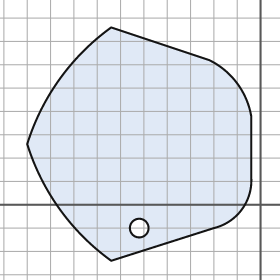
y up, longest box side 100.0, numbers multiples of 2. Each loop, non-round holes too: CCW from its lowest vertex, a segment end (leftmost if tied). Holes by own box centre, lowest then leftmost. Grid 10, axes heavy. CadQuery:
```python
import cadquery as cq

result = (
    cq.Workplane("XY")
    .moveTo(-64.0, -24.0)
    .lineTo(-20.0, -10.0)
    .threePointArc((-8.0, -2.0), (-4.0, 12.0))
    .lineTo(-4.0, 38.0)
    .threePointArc((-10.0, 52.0), (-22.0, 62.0))
    .lineTo(-64.0, 76.0)
    .threePointArc((-86.0, 54.0), (-100.0, 26.0))
    .threePointArc((-86.0, -2.0), (-64.0, -24.0))
    .close()
    .moveTo(-52.0, -10.0)
    .circle(4.0)
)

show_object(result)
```